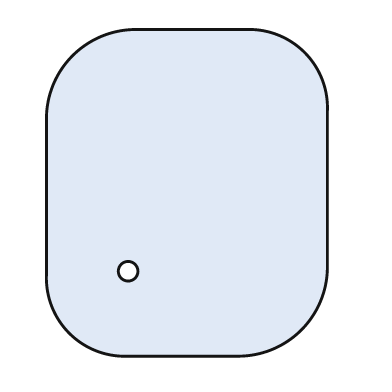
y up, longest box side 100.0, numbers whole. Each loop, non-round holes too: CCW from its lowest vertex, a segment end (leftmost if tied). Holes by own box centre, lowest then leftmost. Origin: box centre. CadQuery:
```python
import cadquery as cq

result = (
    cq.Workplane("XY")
    .moveTo(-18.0, -50.0)
    .lineTo(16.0, -50.0)
    .threePointArc((35.0, -42.0), (43.0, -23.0))
    .lineTo(43.0, 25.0)
    .threePointArc((36.0, 43.0), (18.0, 50.0))
    .lineTo(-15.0, 50.0)
    .threePointArc((-35.0, 42.0), (-43.0, 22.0))
    .lineTo(-43.0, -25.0)
    .threePointArc((-36.0, -43.0), (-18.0, -50.0))
    .close()
    .moveTo(-18.0, -24.0)
    .circle(3.0)
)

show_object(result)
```